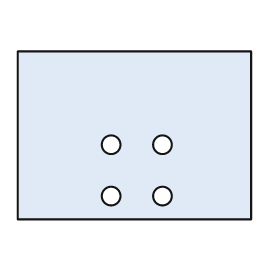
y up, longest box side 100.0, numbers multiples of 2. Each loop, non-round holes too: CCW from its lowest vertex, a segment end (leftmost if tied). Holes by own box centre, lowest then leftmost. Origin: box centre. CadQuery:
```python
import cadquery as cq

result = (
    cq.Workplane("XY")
    .moveTo(-50.0, -36.0)
    .lineTo(50.0, -36.0)
    .lineTo(50.0, 36.0)
    .lineTo(-50.0, 36.0)
    .close()
    .moveTo(-10.0, -26.0)
    .circle(4.0)
    .moveTo(12.0, -26.0)
    .circle(4.0)
    .moveTo(-10.0, -4.0)
    .circle(4.0)
    .moveTo(12.0, -4.0)
    .circle(4.0)
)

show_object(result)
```